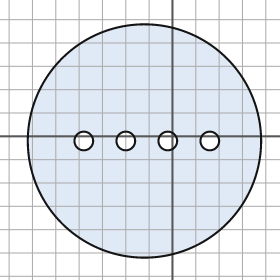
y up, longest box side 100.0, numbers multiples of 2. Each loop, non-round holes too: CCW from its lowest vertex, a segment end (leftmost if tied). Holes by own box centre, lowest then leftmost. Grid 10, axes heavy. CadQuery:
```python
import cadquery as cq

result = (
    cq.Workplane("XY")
    .moveTo(-12.0, -2.0)
    .circle(50.0)
    .moveTo(-38.0, -2.0)
    .circle(4.0)
    .moveTo(-20.0, -2.0)
    .circle(4.0)
    .moveTo(-2.0, -2.0)
    .circle(4.0)
    .moveTo(16.0, -2.0)
    .circle(4.0)
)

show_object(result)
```